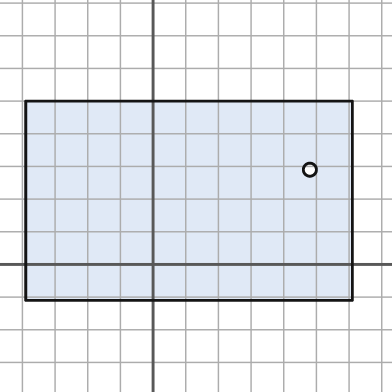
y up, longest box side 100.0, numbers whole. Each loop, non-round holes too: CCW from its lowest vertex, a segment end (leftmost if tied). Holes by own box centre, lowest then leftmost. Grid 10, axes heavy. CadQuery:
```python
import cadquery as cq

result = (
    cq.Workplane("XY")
    .moveTo(-39.0, -11.0)
    .lineTo(61.0, -11.0)
    .lineTo(61.0, 50.0)
    .lineTo(-39.0, 50.0)
    .close()
    .moveTo(48.0, 29.0)
    .circle(2.0)
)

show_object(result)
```